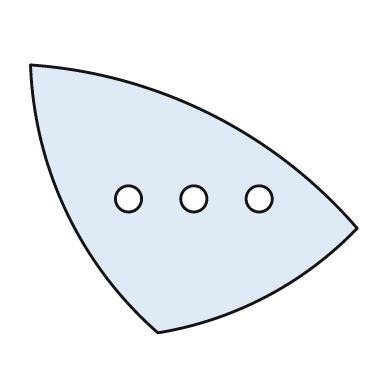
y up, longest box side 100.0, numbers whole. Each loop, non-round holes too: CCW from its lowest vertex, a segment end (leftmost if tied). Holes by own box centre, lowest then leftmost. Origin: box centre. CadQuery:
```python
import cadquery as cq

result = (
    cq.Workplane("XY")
    .moveTo(-11.0, -41.0)
    .threePointArc((22.0, -30.0), (50.0, -9.0))
    .threePointArc((5.0, 26.0), (-50.0, 41.0))
    .threePointArc((-39.0, -4.0), (-11.0, -41.0))
    .close()
    .moveTo(-20.0, 0.0)
    .circle(4.0)
    .moveTo(0.0, 0.0)
    .circle(4.0)
    .moveTo(20.0, 0.0)
    .circle(4.0)
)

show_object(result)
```